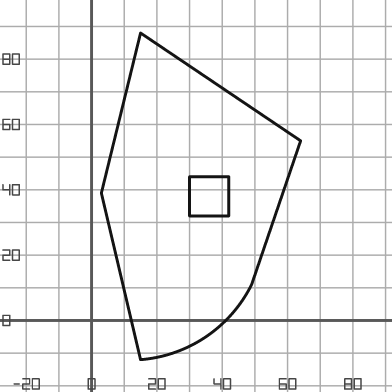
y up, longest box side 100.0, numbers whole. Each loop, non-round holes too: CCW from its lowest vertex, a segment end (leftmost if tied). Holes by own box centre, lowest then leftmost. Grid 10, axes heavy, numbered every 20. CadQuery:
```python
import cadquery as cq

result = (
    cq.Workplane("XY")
    .moveTo(15.0, -12.0)
    .threePointArc((35.0, -5.0), (49.0, 11.0))
    .lineTo(64.0, 55.0)
    .lineTo(15.0, 88.0)
    .lineTo(3.0, 39.0)
    .close()
    .moveTo(30.0, 32.0)
    .lineTo(42.0, 32.0)
    .lineTo(42.0, 44.0)
    .lineTo(30.0, 44.0)
    .close()
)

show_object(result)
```